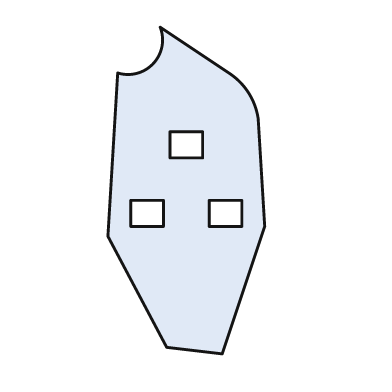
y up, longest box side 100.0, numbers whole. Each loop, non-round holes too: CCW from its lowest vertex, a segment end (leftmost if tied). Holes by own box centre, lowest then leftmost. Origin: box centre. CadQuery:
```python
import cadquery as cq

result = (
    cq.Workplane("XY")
    .moveTo(11.0, -50.0)
    .lineTo(24.0, -11.0)
    .lineTo(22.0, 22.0)
    .threePointArc((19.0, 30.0), (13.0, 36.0))
    .lineTo(-8.0, 50.0)
    .threePointArc((-10.0, 39.0), (-21.0, 36.0))
    .lineTo(-24.0, -14.0)
    .lineTo(-6.0, -48.0)
    .close()
    .moveTo(-17.0, -11.0)
    .lineTo(-7.0, -11.0)
    .lineTo(-7.0, -3.0)
    .lineTo(-17.0, -3.0)
    .close()
    .moveTo(7.0, -11.0)
    .lineTo(17.0, -11.0)
    .lineTo(17.0, -3.0)
    .lineTo(7.0, -3.0)
    .close()
    .moveTo(-5.0, 10.0)
    .lineTo(5.0, 10.0)
    .lineTo(5.0, 18.0)
    .lineTo(-5.0, 18.0)
    .close()
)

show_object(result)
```